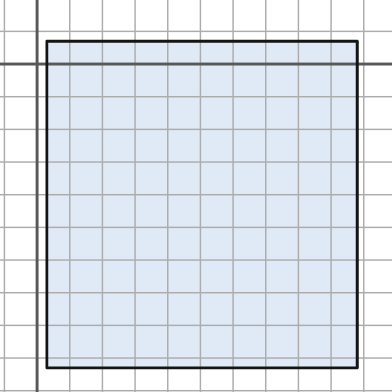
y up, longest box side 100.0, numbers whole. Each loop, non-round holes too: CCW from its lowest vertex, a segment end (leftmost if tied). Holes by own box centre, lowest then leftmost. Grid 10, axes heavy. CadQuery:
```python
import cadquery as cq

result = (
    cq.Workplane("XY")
    .moveTo(3.0, -93.0)
    .lineTo(98.0, -93.0)
    .lineTo(98.0, 7.0)
    .lineTo(3.0, 7.0)
    .close()
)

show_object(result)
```